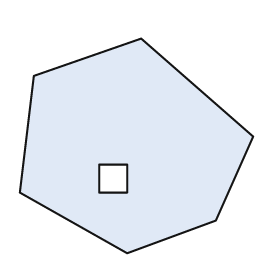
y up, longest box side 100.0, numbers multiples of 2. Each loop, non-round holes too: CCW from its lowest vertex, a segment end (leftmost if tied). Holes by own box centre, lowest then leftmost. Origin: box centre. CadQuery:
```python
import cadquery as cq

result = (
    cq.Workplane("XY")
    .moveTo(-4.0, -46.0)
    .lineTo(34.0, -32.0)
    .lineTo(50.0, 4.0)
    .lineTo(2.0, 46.0)
    .lineTo(-44.0, 30.0)
    .lineTo(-50.0, -20.0)
    .close()
    .moveTo(-16.0, -20.0)
    .lineTo(-4.0, -20.0)
    .lineTo(-4.0, -8.0)
    .lineTo(-16.0, -8.0)
    .close()
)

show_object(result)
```